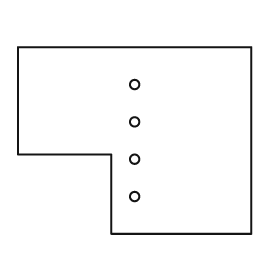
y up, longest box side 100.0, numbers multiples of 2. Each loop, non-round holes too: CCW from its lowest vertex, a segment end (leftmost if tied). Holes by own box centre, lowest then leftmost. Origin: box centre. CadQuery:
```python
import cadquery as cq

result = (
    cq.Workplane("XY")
    .moveTo(-10.0, -40.0)
    .lineTo(50.0, -40.0)
    .lineTo(50.0, 40.0)
    .lineTo(-50.0, 40.0)
    .lineTo(-50.0, -6.0)
    .lineTo(-10.0, -6.0)
    .close()
    .moveTo(0.0, -24.0)
    .circle(2.0)
    .moveTo(0.0, -8.0)
    .circle(2.0)
    .moveTo(0.0, 8.0)
    .circle(2.0)
    .moveTo(0.0, 24.0)
    .circle(2.0)
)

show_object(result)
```